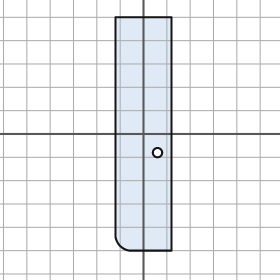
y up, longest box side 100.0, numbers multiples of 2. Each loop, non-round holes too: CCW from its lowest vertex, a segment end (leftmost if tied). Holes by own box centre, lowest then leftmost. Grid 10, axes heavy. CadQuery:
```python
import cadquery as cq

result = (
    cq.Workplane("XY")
    .moveTo(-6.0, -50.0)
    .lineTo(12.0, -50.0)
    .lineTo(12.0, 50.0)
    .lineTo(-12.0, 50.0)
    .lineTo(-12.0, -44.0)
    .threePointArc((-10.0, -48.0), (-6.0, -50.0))
    .close()
    .moveTo(6.0, -8.0)
    .circle(2.0)
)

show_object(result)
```